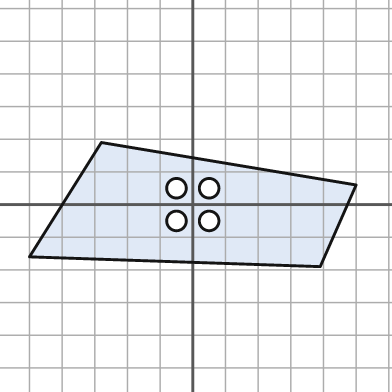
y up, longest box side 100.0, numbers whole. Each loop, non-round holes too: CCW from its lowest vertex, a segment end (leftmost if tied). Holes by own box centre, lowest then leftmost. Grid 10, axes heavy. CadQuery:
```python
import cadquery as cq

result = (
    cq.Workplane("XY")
    .moveTo(39.0, -19.0)
    .lineTo(50.0, 6.0)
    .lineTo(-28.0, 19.0)
    .lineTo(-50.0, -16.0)
    .close()
    .moveTo(-5.0, -5.0)
    .circle(3.0)
    .moveTo(5.0, -5.0)
    .circle(3.0)
    .moveTo(-5.0, 5.0)
    .circle(3.0)
    .moveTo(5.0, 5.0)
    .circle(3.0)
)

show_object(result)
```